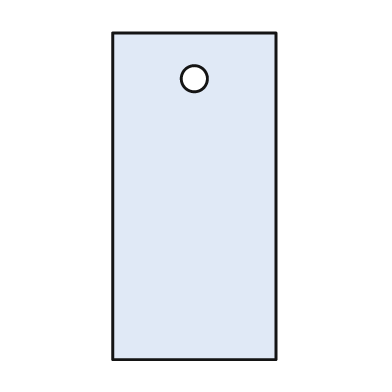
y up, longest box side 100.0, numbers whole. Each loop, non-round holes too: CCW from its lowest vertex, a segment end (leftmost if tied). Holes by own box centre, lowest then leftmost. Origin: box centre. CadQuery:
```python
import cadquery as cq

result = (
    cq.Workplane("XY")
    .moveTo(-25.0, -50.0)
    .lineTo(25.0, -50.0)
    .lineTo(25.0, 50.0)
    .lineTo(-25.0, 50.0)
    .close()
    .moveTo(0.0, 36.0)
    .circle(4.0)
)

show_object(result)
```